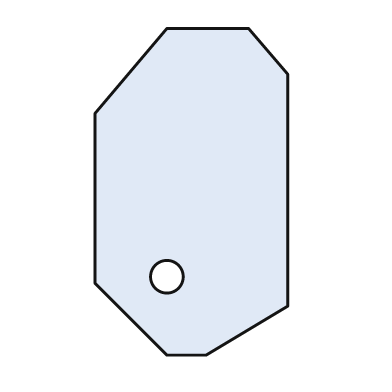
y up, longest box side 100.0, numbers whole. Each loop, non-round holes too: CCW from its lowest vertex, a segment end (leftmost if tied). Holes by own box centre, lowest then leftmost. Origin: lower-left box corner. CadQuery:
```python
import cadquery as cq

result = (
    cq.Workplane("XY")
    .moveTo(22.0, 0.0)
    .lineTo(34.0, 0.0)
    .lineTo(59.0, 15.0)
    .lineTo(59.0, 86.0)
    .lineTo(47.0, 100.0)
    .lineTo(22.0, 100.0)
    .lineTo(0.0, 74.0)
    .lineTo(0.0, 22.0)
    .close()
    .moveTo(22.0, 24.0)
    .circle(5.0)
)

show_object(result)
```